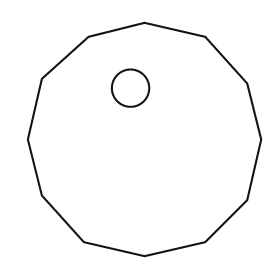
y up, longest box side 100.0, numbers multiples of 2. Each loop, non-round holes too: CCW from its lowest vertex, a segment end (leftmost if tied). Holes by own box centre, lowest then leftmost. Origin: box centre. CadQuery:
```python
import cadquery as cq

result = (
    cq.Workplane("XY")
    .moveTo(0.0, -50.0)
    .lineTo(26.0, -44.0)
    .lineTo(44.0, -26.0)
    .lineTo(50.0, 0.0)
    .lineTo(44.0, 24.0)
    .lineTo(26.0, 44.0)
    .lineTo(0.0, 50.0)
    .lineTo(-24.0, 44.0)
    .lineTo(-44.0, 26.0)
    .lineTo(-50.0, 0.0)
    .lineTo(-44.0, -24.0)
    .lineTo(-26.0, -44.0)
    .close()
    .moveTo(-6.0, 22.0)
    .circle(8.0)
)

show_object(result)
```